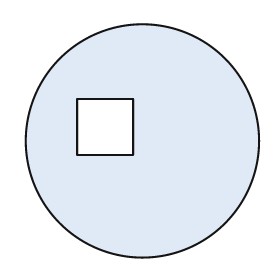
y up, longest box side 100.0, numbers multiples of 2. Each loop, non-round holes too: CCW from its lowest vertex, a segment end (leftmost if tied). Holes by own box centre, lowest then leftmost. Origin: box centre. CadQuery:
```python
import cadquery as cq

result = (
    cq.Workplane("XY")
    .moveTo(0.0, 0.0)
    .circle(50.0)
    .moveTo(-28.0, -6.0)
    .lineTo(-4.0, -6.0)
    .lineTo(-4.0, 18.0)
    .lineTo(-28.0, 18.0)
    .close()
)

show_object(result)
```